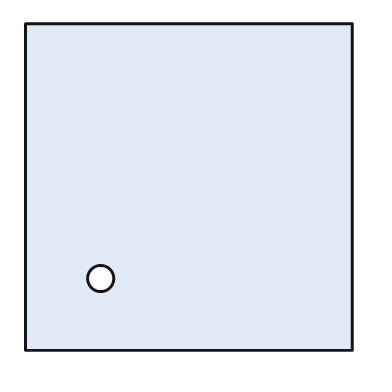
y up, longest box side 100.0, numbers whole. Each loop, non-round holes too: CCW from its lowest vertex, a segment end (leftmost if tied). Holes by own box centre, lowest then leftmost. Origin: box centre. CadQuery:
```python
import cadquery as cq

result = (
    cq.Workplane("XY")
    .moveTo(-50.0, -50.0)
    .lineTo(50.0, -50.0)
    .lineTo(50.0, 50.0)
    .lineTo(-50.0, 50.0)
    .close()
    .moveTo(-27.0, -28.0)
    .circle(4.0)
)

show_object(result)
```